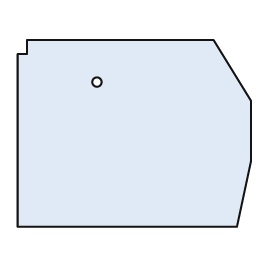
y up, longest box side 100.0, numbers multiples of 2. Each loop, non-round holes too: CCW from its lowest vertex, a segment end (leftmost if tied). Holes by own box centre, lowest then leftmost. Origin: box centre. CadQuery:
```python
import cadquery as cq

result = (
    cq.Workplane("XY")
    .moveTo(-50.0, -40.0)
    .lineTo(44.0, -40.0)
    .lineTo(50.0, -12.0)
    .lineTo(50.0, 14.0)
    .lineTo(34.0, 40.0)
    .lineTo(-46.0, 40.0)
    .lineTo(-46.0, 34.0)
    .lineTo(-50.0, 34.0)
    .close()
    .moveTo(-16.0, 22.0)
    .circle(2.0)
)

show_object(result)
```